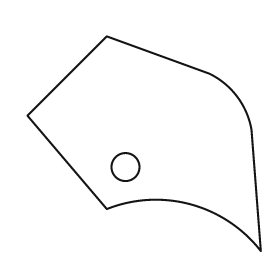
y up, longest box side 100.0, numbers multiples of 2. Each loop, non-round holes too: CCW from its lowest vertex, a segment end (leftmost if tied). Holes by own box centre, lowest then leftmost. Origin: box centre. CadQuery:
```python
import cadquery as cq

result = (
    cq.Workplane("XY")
    .moveTo(50.0, -46.0)
    .lineTo(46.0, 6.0)
    .threePointArc((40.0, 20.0), (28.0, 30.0))
    .lineTo(-16.0, 46.0)
    .lineTo(-50.0, 12.0)
    .lineTo(-16.0, -28.0)
    .threePointArc((20.0, -26.0), (50.0, -46.0))
    .close()
    .moveTo(-8.0, -10.0)
    .circle(6.0)
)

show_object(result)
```